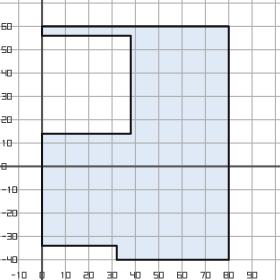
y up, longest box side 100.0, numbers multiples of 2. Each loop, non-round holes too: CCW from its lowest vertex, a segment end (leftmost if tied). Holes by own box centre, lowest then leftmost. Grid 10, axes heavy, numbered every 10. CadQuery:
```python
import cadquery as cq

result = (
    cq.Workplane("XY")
    .moveTo(32.0, -40.0)
    .lineTo(80.0, -40.0)
    .lineTo(80.0, 60.0)
    .lineTo(0.0, 60.0)
    .lineTo(0.0, 56.0)
    .lineTo(38.0, 56.0)
    .lineTo(38.0, 14.0)
    .lineTo(0.0, 14.0)
    .lineTo(0.0, -34.0)
    .lineTo(32.0, -34.0)
    .close()
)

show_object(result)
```